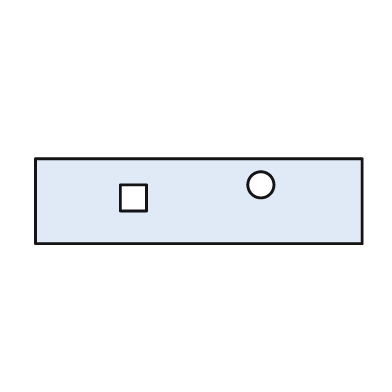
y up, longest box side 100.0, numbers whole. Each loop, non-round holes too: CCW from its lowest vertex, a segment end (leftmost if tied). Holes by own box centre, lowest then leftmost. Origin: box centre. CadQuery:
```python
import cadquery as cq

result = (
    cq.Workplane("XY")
    .moveTo(-50.0, -13.0)
    .lineTo(50.0, -13.0)
    .lineTo(50.0, 13.0)
    .lineTo(-50.0, 13.0)
    .close()
    .moveTo(-24.0, -3.0)
    .lineTo(-16.0, -3.0)
    .lineTo(-16.0, 5.0)
    .lineTo(-24.0, 5.0)
    .close()
    .moveTo(19.0, 5.0)
    .circle(4.0)
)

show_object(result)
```